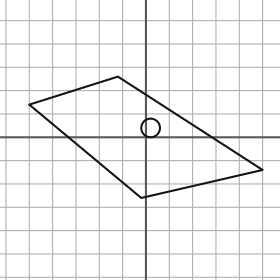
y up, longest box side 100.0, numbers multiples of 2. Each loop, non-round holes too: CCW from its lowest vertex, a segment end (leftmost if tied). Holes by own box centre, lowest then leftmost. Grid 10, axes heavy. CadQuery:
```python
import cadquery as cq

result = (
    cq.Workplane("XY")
    .moveTo(-2.0, -26.0)
    .lineTo(50.0, -14.0)
    .lineTo(-12.0, 26.0)
    .lineTo(-50.0, 14.0)
    .close()
    .moveTo(2.0, 4.0)
    .circle(4.0)
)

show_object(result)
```